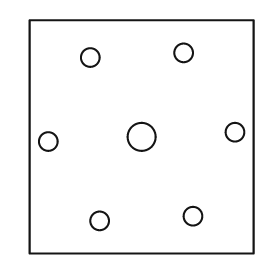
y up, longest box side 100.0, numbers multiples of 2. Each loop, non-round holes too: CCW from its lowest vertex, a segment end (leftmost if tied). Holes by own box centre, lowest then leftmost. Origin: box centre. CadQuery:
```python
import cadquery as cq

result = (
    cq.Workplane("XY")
    .moveTo(-48.0, -50.0)
    .lineTo(48.0, -50.0)
    .lineTo(48.0, 50.0)
    .lineTo(-48.0, 50.0)
    .close()
    .moveTo(-18.0, -36.0)
    .circle(4.0)
    .moveTo(22.0, -34.0)
    .circle(4.0)
    .moveTo(-40.0, -2.0)
    .circle(4.0)
    .moveTo(0.0, 0.0)
    .circle(6.0)
    .moveTo(40.0, 2.0)
    .circle(4.0)
    .moveTo(-22.0, 34.0)
    .circle(4.0)
    .moveTo(18.0, 36.0)
    .circle(4.0)
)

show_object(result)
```